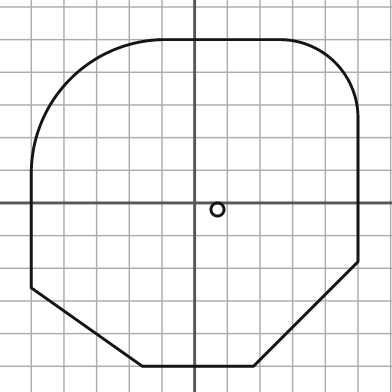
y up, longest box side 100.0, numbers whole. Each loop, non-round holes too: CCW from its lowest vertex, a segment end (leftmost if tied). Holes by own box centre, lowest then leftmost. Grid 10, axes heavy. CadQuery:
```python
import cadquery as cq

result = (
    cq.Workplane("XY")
    .moveTo(-16.0, -50.0)
    .lineTo(18.0, -50.0)
    .lineTo(50.0, -18.0)
    .lineTo(50.0, 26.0)
    .threePointArc((43.0, 43.0), (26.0, 50.0))
    .lineTo(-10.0, 50.0)
    .threePointArc((-38.0, 38.0), (-50.0, 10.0))
    .lineTo(-50.0, -26.0)
    .close()
    .moveTo(7.0, -2.0)
    .circle(2.0)
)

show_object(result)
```